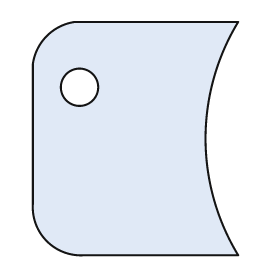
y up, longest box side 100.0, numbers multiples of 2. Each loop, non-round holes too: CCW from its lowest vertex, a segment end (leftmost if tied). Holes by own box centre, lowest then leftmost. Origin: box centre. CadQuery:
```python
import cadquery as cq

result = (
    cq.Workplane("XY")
    .moveTo(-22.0, -50.0)
    .lineTo(44.0, -50.0)
    .threePointArc((30.0, 0.0), (44.0, 50.0))
    .lineTo(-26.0, 50.0)
    .threePointArc((-38.0, 44.0), (-44.0, 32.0))
    .lineTo(-44.0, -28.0)
    .threePointArc((-38.0, -44.0), (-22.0, -50.0))
    .close()
    .moveTo(-24.0, 22.0)
    .circle(8.0)
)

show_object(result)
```